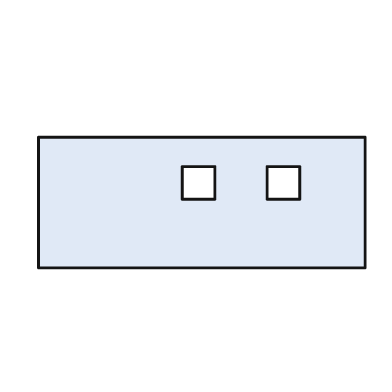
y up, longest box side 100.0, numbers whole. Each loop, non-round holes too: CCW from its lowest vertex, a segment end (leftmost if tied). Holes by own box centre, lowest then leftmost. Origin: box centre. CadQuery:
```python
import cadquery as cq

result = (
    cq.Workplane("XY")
    .moveTo(-50.0, -20.0)
    .lineTo(50.0, -20.0)
    .lineTo(50.0, 20.0)
    .lineTo(-50.0, 20.0)
    .close()
    .moveTo(-6.0, 1.0)
    .lineTo(4.0, 1.0)
    .lineTo(4.0, 11.0)
    .lineTo(-6.0, 11.0)
    .close()
    .moveTo(20.0, 1.0)
    .lineTo(30.0, 1.0)
    .lineTo(30.0, 11.0)
    .lineTo(20.0, 11.0)
    .close()
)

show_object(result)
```